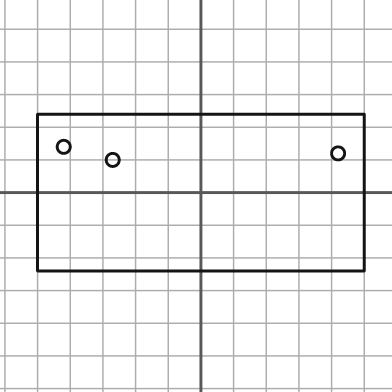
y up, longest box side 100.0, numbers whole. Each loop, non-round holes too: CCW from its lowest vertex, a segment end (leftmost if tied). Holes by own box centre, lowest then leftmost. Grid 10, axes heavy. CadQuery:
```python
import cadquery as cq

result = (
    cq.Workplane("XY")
    .moveTo(-50.0, -24.0)
    .lineTo(50.0, -24.0)
    .lineTo(50.0, 24.0)
    .lineTo(-50.0, 24.0)
    .close()
    .moveTo(-27.0, 10.0)
    .circle(2.0)
    .moveTo(42.0, 12.0)
    .circle(2.0)
    .moveTo(-42.0, 14.0)
    .circle(2.0)
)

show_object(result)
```